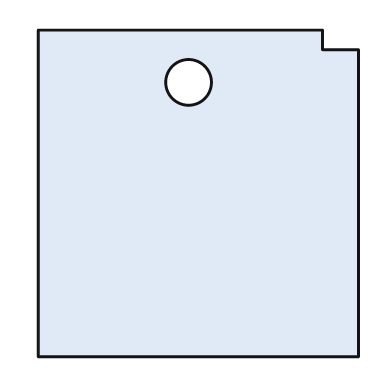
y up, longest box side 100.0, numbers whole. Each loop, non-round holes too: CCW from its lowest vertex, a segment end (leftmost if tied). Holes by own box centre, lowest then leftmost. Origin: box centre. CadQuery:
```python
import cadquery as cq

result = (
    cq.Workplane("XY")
    .moveTo(-49.0, -50.0)
    .lineTo(49.0, -50.0)
    .lineTo(49.0, 44.0)
    .lineTo(38.0, 44.0)
    .lineTo(38.0, 50.0)
    .lineTo(-49.0, 50.0)
    .close()
    .moveTo(-3.0, 34.0)
    .circle(7.0)
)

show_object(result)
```